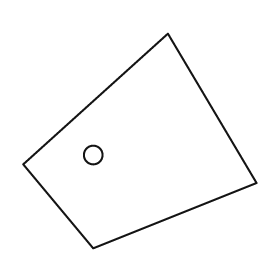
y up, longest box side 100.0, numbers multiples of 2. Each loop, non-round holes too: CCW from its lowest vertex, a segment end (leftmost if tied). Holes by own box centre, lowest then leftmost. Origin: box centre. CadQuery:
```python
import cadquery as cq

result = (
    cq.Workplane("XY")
    .moveTo(-20.0, -46.0)
    .lineTo(50.0, -18.0)
    .lineTo(12.0, 46.0)
    .lineTo(-50.0, -10.0)
    .close()
    .moveTo(-20.0, -6.0)
    .circle(4.0)
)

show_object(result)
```